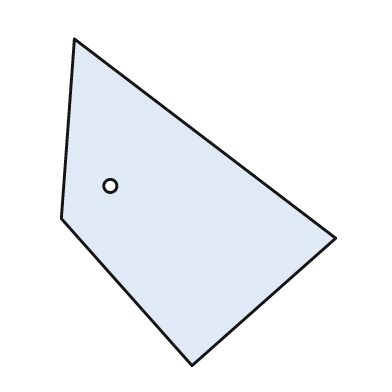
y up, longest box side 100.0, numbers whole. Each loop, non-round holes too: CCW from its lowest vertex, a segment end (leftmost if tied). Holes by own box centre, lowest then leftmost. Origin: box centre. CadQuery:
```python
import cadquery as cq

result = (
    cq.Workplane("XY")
    .moveTo(-2.0, -50.0)
    .lineTo(42.0, -11.0)
    .lineTo(-38.0, 50.0)
    .lineTo(-42.0, -5.0)
    .close()
    .moveTo(-27.0, 5.0)
    .circle(2.0)
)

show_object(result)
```